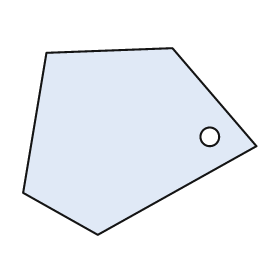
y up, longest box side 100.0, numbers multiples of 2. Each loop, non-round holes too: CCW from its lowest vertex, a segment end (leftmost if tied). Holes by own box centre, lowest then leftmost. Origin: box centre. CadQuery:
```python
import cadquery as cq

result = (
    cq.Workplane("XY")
    .moveTo(-18.0, -40.0)
    .lineTo(50.0, -2.0)
    .lineTo(14.0, 40.0)
    .lineTo(-40.0, 38.0)
    .lineTo(-50.0, -22.0)
    .close()
    .moveTo(30.0, 2.0)
    .circle(4.0)
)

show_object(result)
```